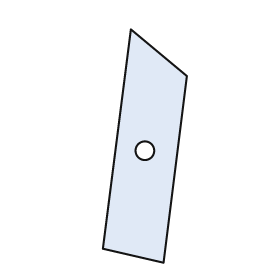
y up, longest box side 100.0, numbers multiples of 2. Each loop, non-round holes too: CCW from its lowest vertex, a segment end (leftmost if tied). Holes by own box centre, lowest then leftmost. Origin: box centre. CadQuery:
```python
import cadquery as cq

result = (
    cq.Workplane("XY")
    .moveTo(8.0, -50.0)
    .lineTo(18.0, 30.0)
    .lineTo(-6.0, 50.0)
    .lineTo(-18.0, -44.0)
    .close()
    .moveTo(0.0, -2.0)
    .circle(4.0)
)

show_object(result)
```